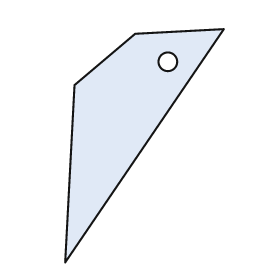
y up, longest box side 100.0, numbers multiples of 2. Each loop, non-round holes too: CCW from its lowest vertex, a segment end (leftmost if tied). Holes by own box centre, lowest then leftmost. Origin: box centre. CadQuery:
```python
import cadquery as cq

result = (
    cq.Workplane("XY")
    .moveTo(-34.0, -50.0)
    .lineTo(34.0, 50.0)
    .lineTo(-4.0, 48.0)
    .lineTo(-30.0, 26.0)
    .close()
    .moveTo(10.0, 36.0)
    .circle(4.0)
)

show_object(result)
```